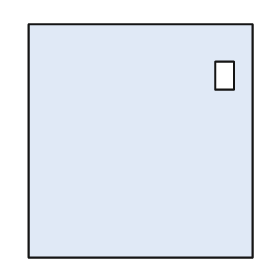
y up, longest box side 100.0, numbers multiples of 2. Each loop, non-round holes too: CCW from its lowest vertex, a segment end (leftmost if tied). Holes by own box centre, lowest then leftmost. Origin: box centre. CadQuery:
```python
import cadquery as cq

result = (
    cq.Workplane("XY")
    .moveTo(-48.0, -50.0)
    .lineTo(48.0, -50.0)
    .lineTo(48.0, 50.0)
    .lineTo(-48.0, 50.0)
    .close()
    .moveTo(32.0, 22.0)
    .lineTo(40.0, 22.0)
    .lineTo(40.0, 34.0)
    .lineTo(32.0, 34.0)
    .close()
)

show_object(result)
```